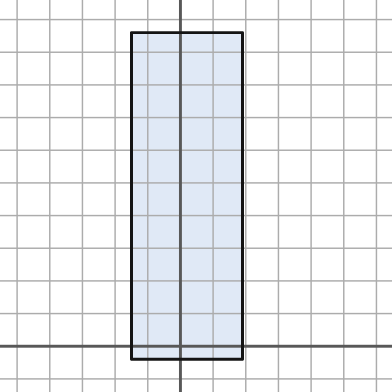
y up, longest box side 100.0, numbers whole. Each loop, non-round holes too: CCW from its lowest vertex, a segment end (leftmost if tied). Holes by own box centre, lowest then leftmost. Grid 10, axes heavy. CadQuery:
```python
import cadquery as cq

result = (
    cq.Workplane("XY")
    .moveTo(-15.0, -4.0)
    .lineTo(19.0, -4.0)
    .lineTo(19.0, 96.0)
    .lineTo(-15.0, 96.0)
    .close()
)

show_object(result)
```